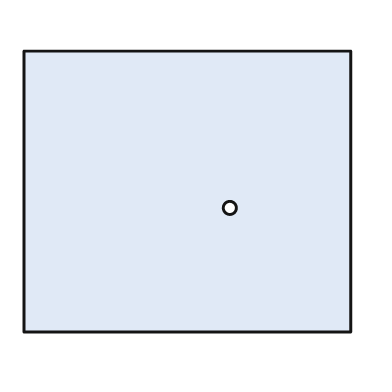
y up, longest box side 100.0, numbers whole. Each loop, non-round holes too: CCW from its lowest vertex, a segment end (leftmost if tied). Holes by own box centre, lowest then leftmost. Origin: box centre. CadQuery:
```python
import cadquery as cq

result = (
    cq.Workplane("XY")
    .moveTo(-50.0, -43.0)
    .lineTo(50.0, -43.0)
    .lineTo(50.0, 43.0)
    .lineTo(-50.0, 43.0)
    .close()
    .moveTo(13.0, -5.0)
    .circle(2.0)
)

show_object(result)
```